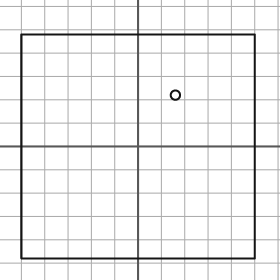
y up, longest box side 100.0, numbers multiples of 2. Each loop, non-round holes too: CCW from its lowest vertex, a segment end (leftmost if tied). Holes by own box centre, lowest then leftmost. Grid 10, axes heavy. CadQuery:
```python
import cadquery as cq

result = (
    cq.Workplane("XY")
    .moveTo(-50.0, -48.0)
    .lineTo(50.0, -48.0)
    .lineTo(50.0, 48.0)
    .lineTo(-50.0, 48.0)
    .close()
    .moveTo(16.0, 22.0)
    .circle(2.0)
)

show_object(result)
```